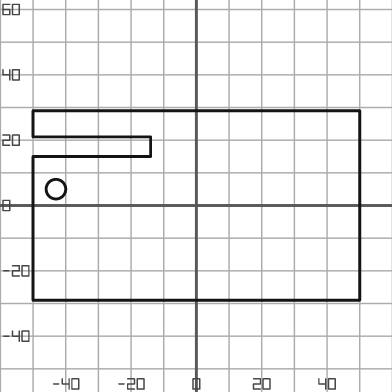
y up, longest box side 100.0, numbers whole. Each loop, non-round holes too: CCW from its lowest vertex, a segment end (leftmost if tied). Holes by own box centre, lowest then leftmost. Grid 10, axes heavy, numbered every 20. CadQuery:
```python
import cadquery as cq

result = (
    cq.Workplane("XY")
    .moveTo(-50.0, -29.0)
    .lineTo(50.0, -29.0)
    .lineTo(50.0, 29.0)
    .lineTo(-50.0, 29.0)
    .lineTo(-50.0, 21.0)
    .lineTo(-14.0, 21.0)
    .lineTo(-14.0, 15.0)
    .lineTo(-50.0, 15.0)
    .close()
    .moveTo(-43.0, 5.0)
    .circle(3.0)
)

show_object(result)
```